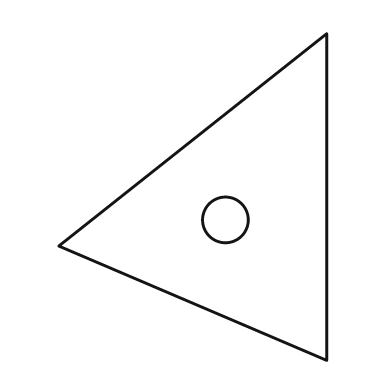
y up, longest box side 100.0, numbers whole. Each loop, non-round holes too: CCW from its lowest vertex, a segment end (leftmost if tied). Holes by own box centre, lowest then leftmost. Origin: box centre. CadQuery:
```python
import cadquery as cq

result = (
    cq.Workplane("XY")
    .moveTo(41.0, -50.0)
    .lineTo(41.0, 50.0)
    .lineTo(-41.0, -15.0)
    .close()
    .moveTo(10.0, -7.0)
    .circle(7.0)
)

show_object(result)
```